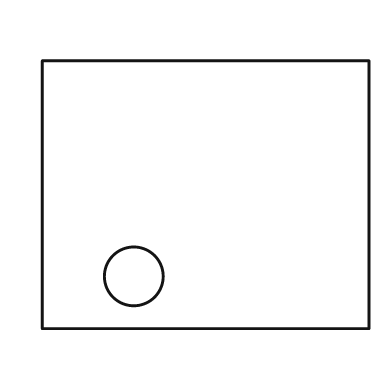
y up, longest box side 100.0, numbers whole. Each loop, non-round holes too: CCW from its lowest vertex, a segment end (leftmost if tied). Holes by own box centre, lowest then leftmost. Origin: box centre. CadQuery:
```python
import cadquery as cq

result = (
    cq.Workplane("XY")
    .moveTo(-50.0, -41.0)
    .lineTo(50.0, -41.0)
    .lineTo(50.0, 41.0)
    .lineTo(-50.0, 41.0)
    .close()
    .moveTo(-22.0, -25.0)
    .circle(9.0)
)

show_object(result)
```